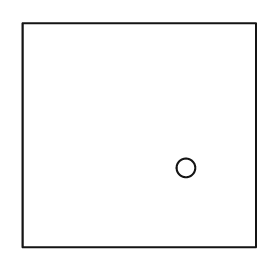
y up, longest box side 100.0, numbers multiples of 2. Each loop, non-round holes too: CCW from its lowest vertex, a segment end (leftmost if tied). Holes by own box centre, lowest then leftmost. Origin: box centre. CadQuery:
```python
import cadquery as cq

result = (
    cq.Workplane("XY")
    .moveTo(-50.0, -48.0)
    .lineTo(50.0, -48.0)
    .lineTo(50.0, 48.0)
    .lineTo(-50.0, 48.0)
    .close()
    .moveTo(20.0, -14.0)
    .circle(4.0)
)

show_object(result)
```